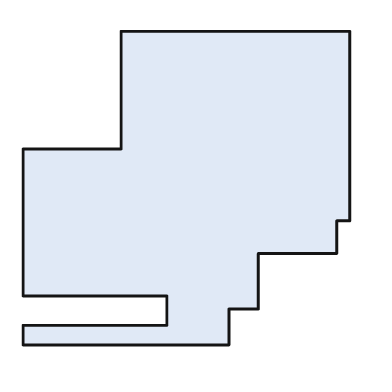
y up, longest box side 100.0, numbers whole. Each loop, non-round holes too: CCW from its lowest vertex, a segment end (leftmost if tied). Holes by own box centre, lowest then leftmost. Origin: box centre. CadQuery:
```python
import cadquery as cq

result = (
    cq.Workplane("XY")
    .moveTo(-50.0, -48.0)
    .lineTo(13.0, -48.0)
    .lineTo(13.0, -37.0)
    .lineTo(22.0, -37.0)
    .lineTo(22.0, -20.0)
    .lineTo(46.0, -20.0)
    .lineTo(46.0, -10.0)
    .lineTo(50.0, -10.0)
    .lineTo(50.0, 48.0)
    .lineTo(-20.0, 48.0)
    .lineTo(-20.0, 12.0)
    .lineTo(-50.0, 12.0)
    .lineTo(-50.0, -33.0)
    .lineTo(-6.0, -33.0)
    .lineTo(-6.0, -42.0)
    .lineTo(-50.0, -42.0)
    .close()
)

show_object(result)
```